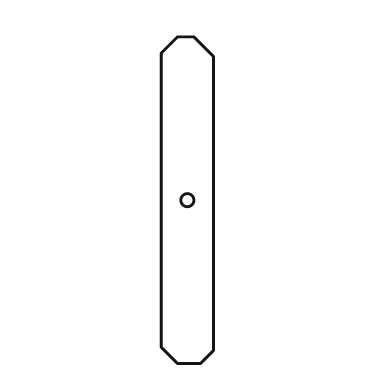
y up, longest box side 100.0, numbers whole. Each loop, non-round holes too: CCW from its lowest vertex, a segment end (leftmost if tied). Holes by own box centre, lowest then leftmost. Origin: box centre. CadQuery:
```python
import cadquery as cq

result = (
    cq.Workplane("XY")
    .moveTo(-3.0, -50.0)
    .lineTo(4.0, -50.0)
    .lineTo(8.0, -46.0)
    .lineTo(8.0, 44.0)
    .lineTo(2.0, 50.0)
    .lineTo(-3.0, 50.0)
    .lineTo(-8.0, 45.0)
    .lineTo(-8.0, -45.0)
    .close()
    .moveTo(0.0, 0.0)
    .circle(2.0)
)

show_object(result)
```